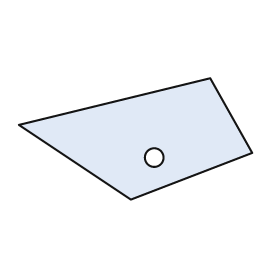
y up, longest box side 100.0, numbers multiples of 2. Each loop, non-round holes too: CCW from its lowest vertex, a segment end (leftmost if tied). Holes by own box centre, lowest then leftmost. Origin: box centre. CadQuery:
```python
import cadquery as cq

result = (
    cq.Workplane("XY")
    .moveTo(-2.0, -26.0)
    .lineTo(50.0, -6.0)
    .lineTo(32.0, 26.0)
    .lineTo(-50.0, 6.0)
    .close()
    .moveTo(8.0, -8.0)
    .circle(4.0)
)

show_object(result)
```